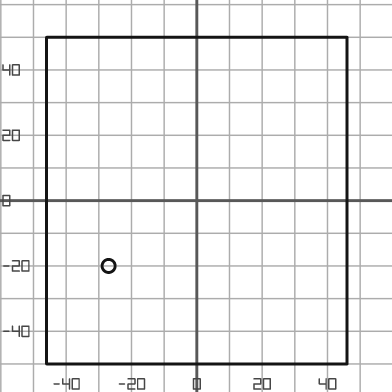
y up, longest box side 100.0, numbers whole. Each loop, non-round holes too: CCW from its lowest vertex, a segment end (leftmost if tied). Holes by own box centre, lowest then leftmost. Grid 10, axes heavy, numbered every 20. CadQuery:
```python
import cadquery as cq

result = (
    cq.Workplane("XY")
    .moveTo(-46.0, -50.0)
    .lineTo(46.0, -50.0)
    .lineTo(46.0, 50.0)
    .lineTo(-46.0, 50.0)
    .close()
    .moveTo(-27.0, -20.0)
    .circle(2.0)
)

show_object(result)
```